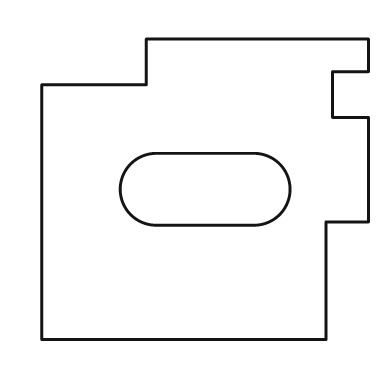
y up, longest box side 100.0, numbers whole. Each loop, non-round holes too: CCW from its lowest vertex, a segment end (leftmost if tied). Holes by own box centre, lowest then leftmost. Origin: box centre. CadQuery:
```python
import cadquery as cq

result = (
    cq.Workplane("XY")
    .moveTo(-50.0, -46.0)
    .lineTo(37.0, -46.0)
    .lineTo(37.0, -10.0)
    .lineTo(50.0, -10.0)
    .lineTo(50.0, 22.0)
    .lineTo(39.0, 22.0)
    .lineTo(39.0, 36.0)
    .lineTo(50.0, 36.0)
    .lineTo(50.0, 46.0)
    .lineTo(-18.0, 46.0)
    .lineTo(-18.0, 32.0)
    .lineTo(-50.0, 32.0)
    .close()
    .moveTo(-15.0, -11.0)
    .lineTo(15.0, -11.0)
    .threePointArc((26.0, 0.0), (15.0, 11.0))
    .lineTo(-15.0, 11.0)
    .threePointArc((-26.0, 0.0), (-15.0, -11.0))
    .close()
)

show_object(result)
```